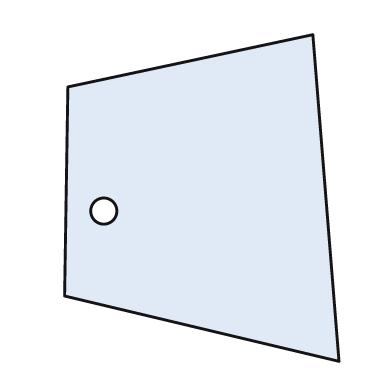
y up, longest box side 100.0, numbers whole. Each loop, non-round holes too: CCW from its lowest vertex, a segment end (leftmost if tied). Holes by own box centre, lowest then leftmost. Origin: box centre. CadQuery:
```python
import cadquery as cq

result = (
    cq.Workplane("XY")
    .moveTo(42.0, -50.0)
    .lineTo(34.0, 50.0)
    .lineTo(-41.0, 34.0)
    .lineTo(-42.0, -30.0)
    .close()
    .moveTo(-30.0, -4.0)
    .circle(4.0)
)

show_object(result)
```